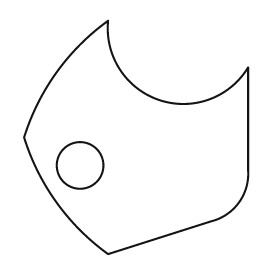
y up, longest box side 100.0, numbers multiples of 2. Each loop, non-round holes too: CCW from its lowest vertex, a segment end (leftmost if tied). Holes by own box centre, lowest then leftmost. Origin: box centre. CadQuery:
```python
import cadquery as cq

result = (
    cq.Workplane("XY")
    .moveTo(-12.0, -50.0)
    .lineTo(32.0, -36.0)
    .threePointArc((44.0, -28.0), (48.0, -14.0))
    .lineTo(48.0, 30.0)
    .threePointArc((10.0, 16.0), (-12.0, 50.0))
    .threePointArc((-34.0, 28.0), (-48.0, 0.0))
    .threePointArc((-34.0, -28.0), (-12.0, -50.0))
    .close()
    .moveTo(-24.0, -12.0)
    .circle(10.0)
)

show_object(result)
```